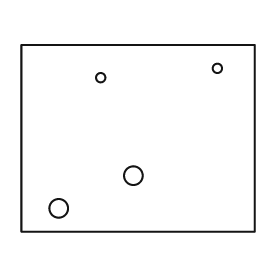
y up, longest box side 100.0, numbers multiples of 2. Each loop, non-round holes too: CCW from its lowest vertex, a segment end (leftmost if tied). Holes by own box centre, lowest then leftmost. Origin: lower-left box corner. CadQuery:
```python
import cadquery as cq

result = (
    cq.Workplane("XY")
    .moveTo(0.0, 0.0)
    .lineTo(100.0, 0.0)
    .lineTo(100.0, 80.0)
    .lineTo(0.0, 80.0)
    .close()
    .moveTo(16.0, 10.0)
    .circle(4.0)
    .moveTo(48.0, 24.0)
    .circle(4.0)
    .moveTo(34.0, 66.0)
    .circle(2.0)
    .moveTo(84.0, 70.0)
    .circle(2.0)
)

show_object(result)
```